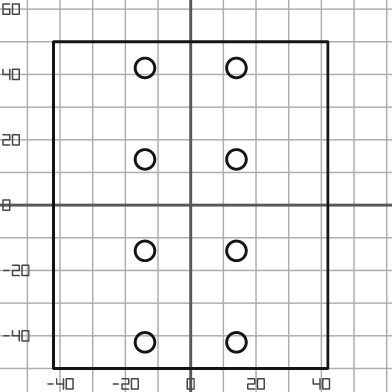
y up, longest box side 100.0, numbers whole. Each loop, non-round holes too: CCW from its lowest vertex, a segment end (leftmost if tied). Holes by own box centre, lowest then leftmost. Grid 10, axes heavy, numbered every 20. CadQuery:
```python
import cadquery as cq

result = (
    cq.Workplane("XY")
    .moveTo(-42.0, -50.0)
    .lineTo(42.0, -50.0)
    .lineTo(42.0, 50.0)
    .lineTo(-42.0, 50.0)
    .close()
    .moveTo(-14.0, -42.0)
    .circle(3.0)
    .moveTo(14.0, -42.0)
    .circle(3.0)
    .moveTo(-14.0, -14.0)
    .circle(3.0)
    .moveTo(14.0, -14.0)
    .circle(3.0)
    .moveTo(-14.0, 14.0)
    .circle(3.0)
    .moveTo(14.0, 14.0)
    .circle(3.0)
    .moveTo(-14.0, 42.0)
    .circle(3.0)
    .moveTo(14.0, 42.0)
    .circle(3.0)
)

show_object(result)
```